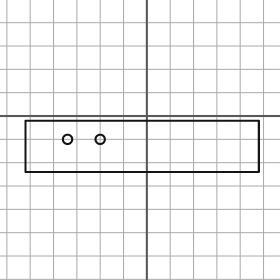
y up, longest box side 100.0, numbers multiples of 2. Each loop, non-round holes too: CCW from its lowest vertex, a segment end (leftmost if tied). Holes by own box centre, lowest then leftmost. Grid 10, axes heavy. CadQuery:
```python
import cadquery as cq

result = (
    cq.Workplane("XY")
    .moveTo(-52.0, -24.0)
    .lineTo(48.0, -24.0)
    .lineTo(48.0, -2.0)
    .lineTo(-52.0, -2.0)
    .close()
    .moveTo(-34.0, -10.0)
    .circle(2.0)
    .moveTo(-20.0, -10.0)
    .circle(2.0)
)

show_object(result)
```